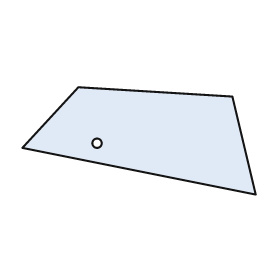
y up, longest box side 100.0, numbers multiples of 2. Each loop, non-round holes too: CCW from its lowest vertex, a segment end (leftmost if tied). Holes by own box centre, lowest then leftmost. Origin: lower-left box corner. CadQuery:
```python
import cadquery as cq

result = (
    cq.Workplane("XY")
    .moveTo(100.0, 0.0)
    .lineTo(90.0, 42.0)
    .lineTo(24.0, 46.0)
    .lineTo(0.0, 20.0)
    .close()
    .moveTo(32.0, 22.0)
    .circle(2.0)
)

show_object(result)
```